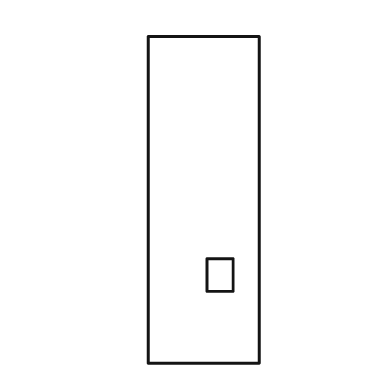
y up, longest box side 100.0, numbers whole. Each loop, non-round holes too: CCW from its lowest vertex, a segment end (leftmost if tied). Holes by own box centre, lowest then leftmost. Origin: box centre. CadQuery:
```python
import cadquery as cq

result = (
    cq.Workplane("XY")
    .moveTo(-17.0, -50.0)
    .lineTo(17.0, -50.0)
    .lineTo(17.0, 50.0)
    .lineTo(-17.0, 50.0)
    .close()
    .moveTo(1.0, -28.0)
    .lineTo(9.0, -28.0)
    .lineTo(9.0, -18.0)
    .lineTo(1.0, -18.0)
    .close()
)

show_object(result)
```